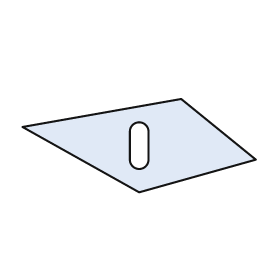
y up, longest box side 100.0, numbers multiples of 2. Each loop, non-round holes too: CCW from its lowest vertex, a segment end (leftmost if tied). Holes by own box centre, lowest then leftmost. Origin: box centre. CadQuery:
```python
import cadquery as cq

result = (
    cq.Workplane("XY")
    .moveTo(0.0, -20.0)
    .lineTo(50.0, -6.0)
    .lineTo(18.0, 20.0)
    .lineTo(-50.0, 8.0)
    .close()
    .moveTo(-4.0, -6.0)
    .threePointArc((0.0, -10.0), (4.0, -6.0))
    .lineTo(4.0, 6.0)
    .threePointArc((0.0, 10.0), (-4.0, 6.0))
    .close()
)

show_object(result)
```